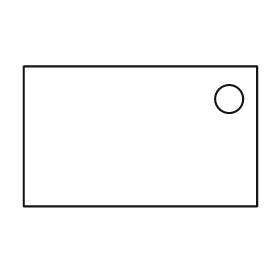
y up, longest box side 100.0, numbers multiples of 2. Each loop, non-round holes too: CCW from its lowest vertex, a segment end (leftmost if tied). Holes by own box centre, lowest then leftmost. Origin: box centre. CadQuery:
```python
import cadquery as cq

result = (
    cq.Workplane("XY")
    .moveTo(-50.0, -30.0)
    .lineTo(50.0, -30.0)
    .lineTo(50.0, 30.0)
    .lineTo(-50.0, 30.0)
    .close()
    .moveTo(38.0, 16.0)
    .circle(6.0)
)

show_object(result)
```